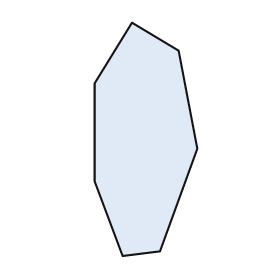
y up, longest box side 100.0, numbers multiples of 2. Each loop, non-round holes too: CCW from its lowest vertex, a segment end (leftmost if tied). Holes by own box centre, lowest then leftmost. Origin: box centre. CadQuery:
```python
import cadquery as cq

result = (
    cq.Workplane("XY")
    .moveTo(-10.0, -50.0)
    .lineTo(6.0, -48.0)
    .lineTo(22.0, -4.0)
    .lineTo(14.0, 38.0)
    .lineTo(-6.0, 50.0)
    .lineTo(-22.0, 24.0)
    .lineTo(-22.0, -18.0)
    .close()
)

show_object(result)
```